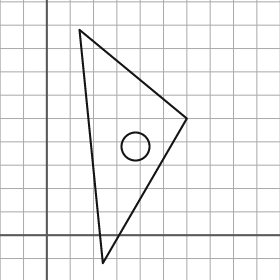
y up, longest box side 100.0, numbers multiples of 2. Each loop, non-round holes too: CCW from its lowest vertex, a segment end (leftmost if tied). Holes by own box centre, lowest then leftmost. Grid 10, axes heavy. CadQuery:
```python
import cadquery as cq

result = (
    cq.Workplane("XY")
    .moveTo(24.0, -12.0)
    .lineTo(60.0, 50.0)
    .lineTo(14.0, 88.0)
    .close()
    .moveTo(38.0, 38.0)
    .circle(6.0)
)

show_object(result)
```